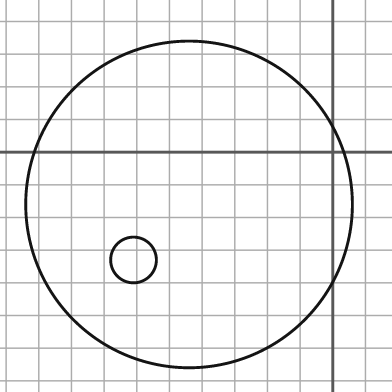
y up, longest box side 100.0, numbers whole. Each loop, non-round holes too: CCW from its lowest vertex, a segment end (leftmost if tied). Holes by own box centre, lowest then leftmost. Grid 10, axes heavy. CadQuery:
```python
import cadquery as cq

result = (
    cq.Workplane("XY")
    .moveTo(-44.0, -16.0)
    .circle(50.0)
    .moveTo(-61.0, -33.0)
    .circle(7.0)
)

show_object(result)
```